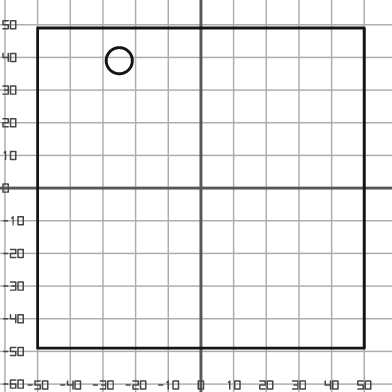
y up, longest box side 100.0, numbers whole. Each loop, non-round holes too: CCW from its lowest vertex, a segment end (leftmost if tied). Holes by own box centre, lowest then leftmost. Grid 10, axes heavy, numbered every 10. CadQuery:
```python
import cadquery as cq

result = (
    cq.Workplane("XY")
    .moveTo(-50.0, -49.0)
    .lineTo(50.0, -49.0)
    .lineTo(50.0, 49.0)
    .lineTo(-50.0, 49.0)
    .close()
    .moveTo(-25.0, 39.0)
    .circle(4.0)
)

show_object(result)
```